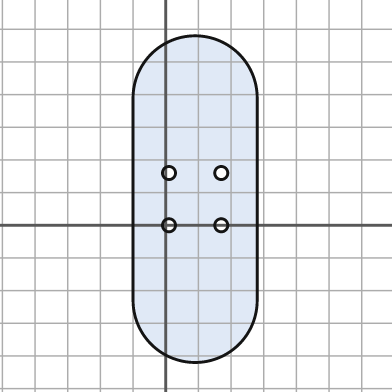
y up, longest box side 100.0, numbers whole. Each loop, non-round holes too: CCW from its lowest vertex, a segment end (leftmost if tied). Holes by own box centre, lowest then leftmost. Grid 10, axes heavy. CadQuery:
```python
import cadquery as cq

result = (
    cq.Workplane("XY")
    .moveTo(-10.0, -23.0)
    .threePointArc((9.0, -42.0), (28.0, -23.0))
    .lineTo(28.0, 39.0)
    .threePointArc((9.0, 58.0), (-10.0, 39.0))
    .close()
    .moveTo(1.0, 0.0)
    .circle(2.0)
    .moveTo(17.0, 0.0)
    .circle(2.0)
    .moveTo(1.0, 16.0)
    .circle(2.0)
    .moveTo(17.0, 16.0)
    .circle(2.0)
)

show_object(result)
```